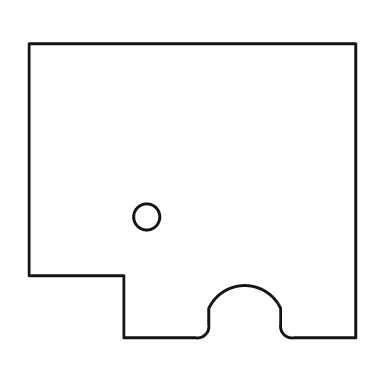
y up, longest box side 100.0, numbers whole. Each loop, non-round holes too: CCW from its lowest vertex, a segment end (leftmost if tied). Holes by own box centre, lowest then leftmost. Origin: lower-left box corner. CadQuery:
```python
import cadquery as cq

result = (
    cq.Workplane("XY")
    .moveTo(29.0, 0.0)
    .lineTo(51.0, 0.0)
    .threePointArc((54.0, 1.0), (55.0, 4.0))
    .lineTo(55.0, 9.0)
    .threePointArc((66.0, 16.0), (77.0, 9.0))
    .lineTo(77.0, 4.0)
    .threePointArc((78.0, 1.0), (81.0, 0.0))
    .lineTo(100.0, 0.0)
    .lineTo(100.0, 90.0)
    .lineTo(0.0, 90.0)
    .lineTo(0.0, 19.0)
    .lineTo(29.0, 19.0)
    .close()
    .moveTo(36.0, 37.0)
    .circle(4.0)
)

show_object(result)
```